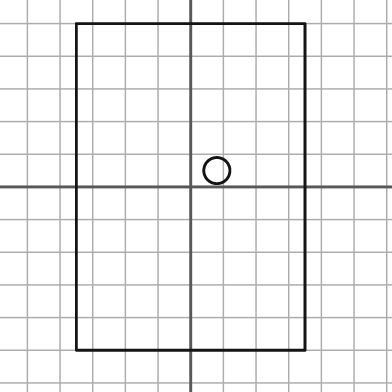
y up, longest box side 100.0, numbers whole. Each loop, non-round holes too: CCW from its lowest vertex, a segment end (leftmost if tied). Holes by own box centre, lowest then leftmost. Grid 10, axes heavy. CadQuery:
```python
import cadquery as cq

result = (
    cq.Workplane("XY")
    .moveTo(-35.0, -50.0)
    .lineTo(35.0, -50.0)
    .lineTo(35.0, 50.0)
    .lineTo(-35.0, 50.0)
    .close()
    .moveTo(8.0, 5.0)
    .circle(4.0)
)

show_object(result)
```